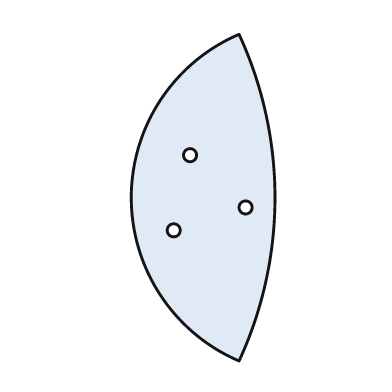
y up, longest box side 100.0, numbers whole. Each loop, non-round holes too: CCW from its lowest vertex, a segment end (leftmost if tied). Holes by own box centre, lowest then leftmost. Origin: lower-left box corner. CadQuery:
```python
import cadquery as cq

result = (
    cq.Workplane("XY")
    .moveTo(33.0, 0.0)
    .threePointArc((44.0, 50.0), (33.0, 100.0))
    .threePointArc((0.0, 50.0), (33.0, 0.0))
    .close()
    .moveTo(13.0, 40.0)
    .circle(2.0)
    .moveTo(35.0, 47.0)
    .circle(2.0)
    .moveTo(18.0, 63.0)
    .circle(2.0)
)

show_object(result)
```